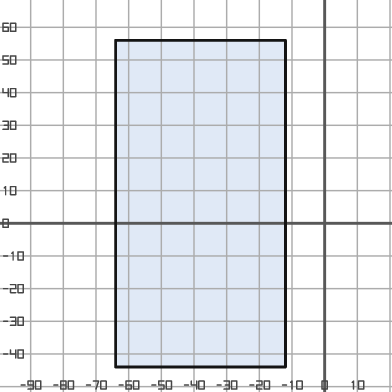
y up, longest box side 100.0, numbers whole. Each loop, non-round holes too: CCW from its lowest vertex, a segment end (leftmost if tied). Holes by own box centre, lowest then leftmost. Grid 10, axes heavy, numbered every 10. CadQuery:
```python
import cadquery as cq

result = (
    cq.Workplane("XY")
    .moveTo(-64.0, -44.0)
    .lineTo(-12.0, -44.0)
    .lineTo(-12.0, 56.0)
    .lineTo(-64.0, 56.0)
    .close()
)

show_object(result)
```